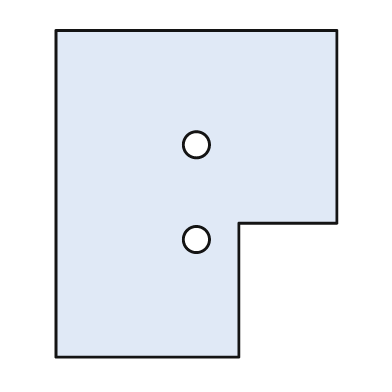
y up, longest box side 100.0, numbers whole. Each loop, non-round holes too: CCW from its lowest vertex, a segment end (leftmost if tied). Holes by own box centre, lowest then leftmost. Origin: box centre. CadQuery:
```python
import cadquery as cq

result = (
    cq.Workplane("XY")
    .moveTo(-43.0, -50.0)
    .lineTo(13.0, -50.0)
    .lineTo(13.0, -9.0)
    .lineTo(43.0, -9.0)
    .lineTo(43.0, 50.0)
    .lineTo(-43.0, 50.0)
    .close()
    .moveTo(0.0, -14.0)
    .circle(4.0)
    .moveTo(0.0, 15.0)
    .circle(4.0)
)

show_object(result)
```